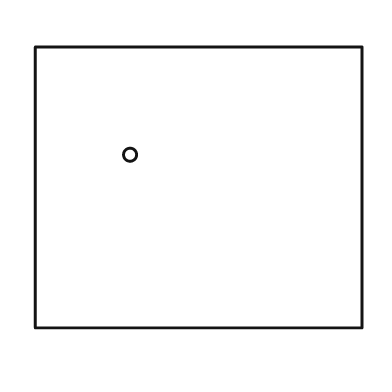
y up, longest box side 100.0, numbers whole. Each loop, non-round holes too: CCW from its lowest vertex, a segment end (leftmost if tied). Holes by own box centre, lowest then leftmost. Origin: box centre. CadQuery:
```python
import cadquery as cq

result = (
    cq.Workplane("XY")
    .moveTo(-50.0, -43.0)
    .lineTo(50.0, -43.0)
    .lineTo(50.0, 43.0)
    .lineTo(-50.0, 43.0)
    .close()
    .moveTo(-21.0, 10.0)
    .circle(2.0)
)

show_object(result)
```